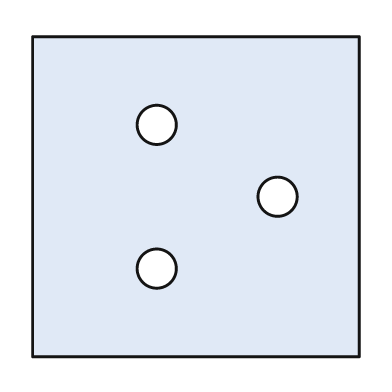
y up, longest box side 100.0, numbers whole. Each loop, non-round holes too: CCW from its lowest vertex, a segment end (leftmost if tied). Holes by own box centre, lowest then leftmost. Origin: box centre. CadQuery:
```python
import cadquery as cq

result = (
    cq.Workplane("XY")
    .moveTo(-50.0, -49.0)
    .lineTo(50.0, -49.0)
    .lineTo(50.0, 49.0)
    .lineTo(-50.0, 49.0)
    .close()
    .moveTo(-12.0, -22.0)
    .circle(6.0)
    .moveTo(25.0, 0.0)
    .circle(6.0)
    .moveTo(-12.0, 22.0)
    .circle(6.0)
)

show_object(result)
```